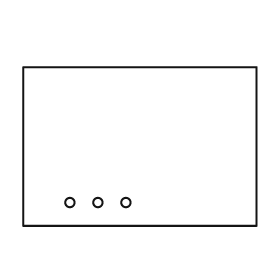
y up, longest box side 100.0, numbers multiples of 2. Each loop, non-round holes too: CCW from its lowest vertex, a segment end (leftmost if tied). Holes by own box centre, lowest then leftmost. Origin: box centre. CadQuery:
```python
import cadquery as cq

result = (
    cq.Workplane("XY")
    .moveTo(-50.0, -34.0)
    .lineTo(50.0, -34.0)
    .lineTo(50.0, 34.0)
    .lineTo(-50.0, 34.0)
    .close()
    .moveTo(-30.0, -24.0)
    .circle(2.0)
    .moveTo(-18.0, -24.0)
    .circle(2.0)
    .moveTo(-6.0, -24.0)
    .circle(2.0)
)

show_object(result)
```